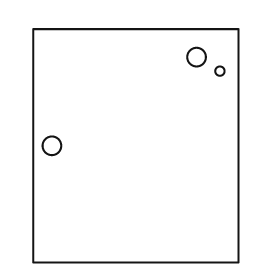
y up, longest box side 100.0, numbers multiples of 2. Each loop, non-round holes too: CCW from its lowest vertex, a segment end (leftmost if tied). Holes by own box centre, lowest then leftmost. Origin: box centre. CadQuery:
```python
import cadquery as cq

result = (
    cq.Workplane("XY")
    .moveTo(-44.0, -50.0)
    .lineTo(44.0, -50.0)
    .lineTo(44.0, 50.0)
    .lineTo(-44.0, 50.0)
    .close()
    .moveTo(-36.0, 0.0)
    .circle(4.0)
    .moveTo(36.0, 32.0)
    .circle(2.0)
    .moveTo(26.0, 38.0)
    .circle(4.0)
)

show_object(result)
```